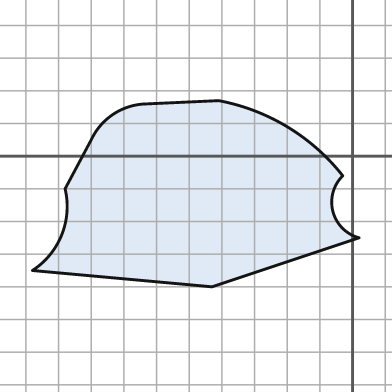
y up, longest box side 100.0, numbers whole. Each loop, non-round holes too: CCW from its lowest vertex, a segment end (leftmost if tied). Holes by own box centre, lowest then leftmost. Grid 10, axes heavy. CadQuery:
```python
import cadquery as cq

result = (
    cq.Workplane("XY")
    .moveTo(-43.0, -40.0)
    .lineTo(2.0, -25.0)
    .threePointArc((-6.0, -17.0), (-3.0, -6.0))
    .threePointArc((-20.0, 9.0), (-41.0, 17.0))
    .lineTo(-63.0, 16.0)
    .threePointArc((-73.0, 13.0), (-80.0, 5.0))
    .lineTo(-88.0, -10.0)
    .threePointArc((-89.0, -24.0), (-98.0, -35.0))
    .close()
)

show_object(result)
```